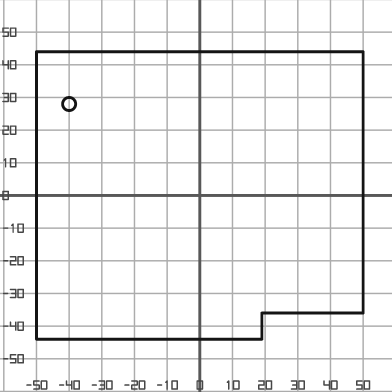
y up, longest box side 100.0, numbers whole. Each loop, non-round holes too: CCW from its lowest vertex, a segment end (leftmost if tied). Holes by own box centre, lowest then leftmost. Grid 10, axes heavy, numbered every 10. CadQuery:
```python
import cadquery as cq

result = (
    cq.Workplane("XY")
    .moveTo(-50.0, -44.0)
    .lineTo(19.0, -44.0)
    .lineTo(19.0, -36.0)
    .lineTo(50.0, -36.0)
    .lineTo(50.0, 44.0)
    .lineTo(-50.0, 44.0)
    .close()
    .moveTo(-40.0, 28.0)
    .circle(2.0)
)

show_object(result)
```